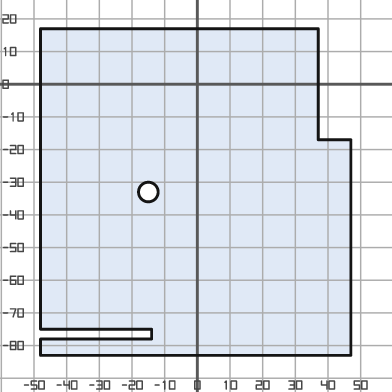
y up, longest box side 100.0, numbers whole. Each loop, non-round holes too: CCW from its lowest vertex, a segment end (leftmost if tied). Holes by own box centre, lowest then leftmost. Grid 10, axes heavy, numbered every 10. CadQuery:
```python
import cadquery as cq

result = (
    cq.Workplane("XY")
    .moveTo(-48.0, -83.0)
    .lineTo(47.0, -83.0)
    .lineTo(47.0, -17.0)
    .lineTo(37.0, -17.0)
    .lineTo(37.0, 17.0)
    .lineTo(-48.0, 17.0)
    .lineTo(-48.0, -75.0)
    .lineTo(-14.0, -75.0)
    .lineTo(-14.0, -78.0)
    .lineTo(-48.0, -78.0)
    .close()
    .moveTo(-15.0, -33.0)
    .circle(3.0)
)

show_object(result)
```